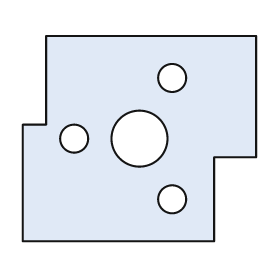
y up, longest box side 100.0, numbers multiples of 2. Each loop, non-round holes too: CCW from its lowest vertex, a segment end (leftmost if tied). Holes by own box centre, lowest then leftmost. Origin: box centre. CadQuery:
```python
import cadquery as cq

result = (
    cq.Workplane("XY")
    .moveTo(-50.0, -44.0)
    .lineTo(32.0, -44.0)
    .lineTo(32.0, -8.0)
    .lineTo(50.0, -8.0)
    .lineTo(50.0, 44.0)
    .lineTo(-40.0, 44.0)
    .lineTo(-40.0, 6.0)
    .lineTo(-50.0, 6.0)
    .close()
    .moveTo(14.0, -26.0)
    .circle(6.0)
    .moveTo(-28.0, 0.0)
    .circle(6.0)
    .moveTo(0.0, 0.0)
    .circle(12.0)
    .moveTo(14.0, 26.0)
    .circle(6.0)
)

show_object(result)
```